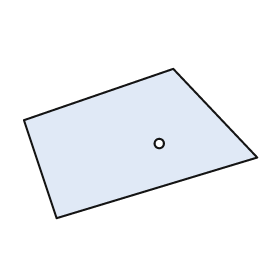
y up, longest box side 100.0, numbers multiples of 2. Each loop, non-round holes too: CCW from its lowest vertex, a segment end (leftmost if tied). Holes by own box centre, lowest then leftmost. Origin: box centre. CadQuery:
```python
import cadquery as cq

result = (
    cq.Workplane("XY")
    .moveTo(-36.0, -32.0)
    .lineTo(50.0, -6.0)
    .lineTo(14.0, 32.0)
    .lineTo(-50.0, 10.0)
    .close()
    .moveTo(8.0, 0.0)
    .circle(2.0)
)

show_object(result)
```